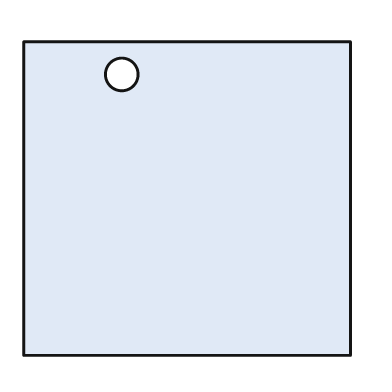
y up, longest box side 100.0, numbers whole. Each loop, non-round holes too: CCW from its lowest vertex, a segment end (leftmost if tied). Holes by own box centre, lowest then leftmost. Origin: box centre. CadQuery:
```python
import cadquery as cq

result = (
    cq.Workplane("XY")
    .moveTo(-50.0, -48.0)
    .lineTo(50.0, -48.0)
    .lineTo(50.0, 48.0)
    .lineTo(-50.0, 48.0)
    .close()
    .moveTo(-20.0, 38.0)
    .circle(5.0)
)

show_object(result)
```